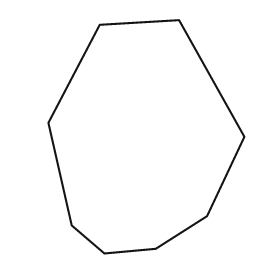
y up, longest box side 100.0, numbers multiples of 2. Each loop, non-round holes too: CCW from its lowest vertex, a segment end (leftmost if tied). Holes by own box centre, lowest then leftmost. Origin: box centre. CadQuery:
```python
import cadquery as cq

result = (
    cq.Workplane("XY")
    .moveTo(-18.0, -50.0)
    .lineTo(4.0, -48.0)
    .lineTo(26.0, -34.0)
    .lineTo(42.0, 0.0)
    .lineTo(14.0, 50.0)
    .lineTo(-20.0, 48.0)
    .lineTo(-42.0, 6.0)
    .lineTo(-32.0, -38.0)
    .close()
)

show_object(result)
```